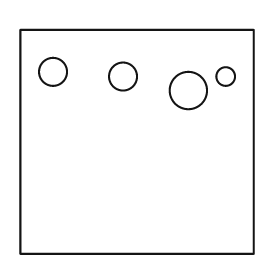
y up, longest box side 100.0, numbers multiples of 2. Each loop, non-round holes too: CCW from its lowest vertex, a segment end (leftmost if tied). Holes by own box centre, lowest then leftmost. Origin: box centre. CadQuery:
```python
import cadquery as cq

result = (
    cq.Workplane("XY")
    .moveTo(-50.0, -48.0)
    .lineTo(50.0, -48.0)
    .lineTo(50.0, 48.0)
    .lineTo(-50.0, 48.0)
    .close()
    .moveTo(22.0, 22.0)
    .circle(8.0)
    .moveTo(-6.0, 28.0)
    .circle(6.0)
    .moveTo(38.0, 28.0)
    .circle(4.0)
    .moveTo(-36.0, 30.0)
    .circle(6.0)
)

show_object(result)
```